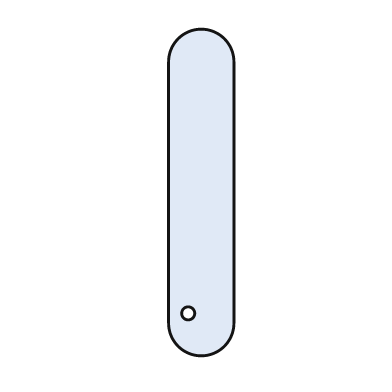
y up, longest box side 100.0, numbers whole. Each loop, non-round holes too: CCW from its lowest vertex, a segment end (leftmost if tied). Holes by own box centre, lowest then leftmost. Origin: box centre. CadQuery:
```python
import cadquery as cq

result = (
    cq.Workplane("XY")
    .moveTo(-10.0, -40.0)
    .threePointArc((0.0, -50.0), (10.0, -40.0))
    .lineTo(10.0, 40.0)
    .threePointArc((0.0, 50.0), (-10.0, 40.0))
    .close()
    .moveTo(-4.0, -37.0)
    .circle(2.0)
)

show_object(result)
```